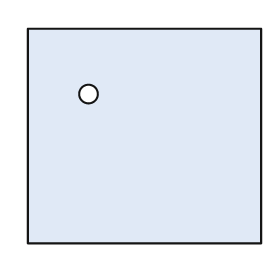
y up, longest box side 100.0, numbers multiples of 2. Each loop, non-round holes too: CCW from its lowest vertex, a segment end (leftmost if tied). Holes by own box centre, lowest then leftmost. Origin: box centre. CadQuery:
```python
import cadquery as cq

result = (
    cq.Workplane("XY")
    .moveTo(-50.0, -46.0)
    .lineTo(50.0, -46.0)
    .lineTo(50.0, 46.0)
    .lineTo(-50.0, 46.0)
    .close()
    .moveTo(-24.0, 18.0)
    .circle(4.0)
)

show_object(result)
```